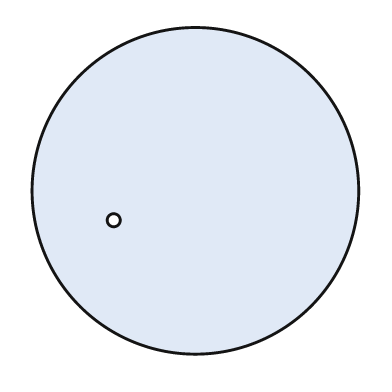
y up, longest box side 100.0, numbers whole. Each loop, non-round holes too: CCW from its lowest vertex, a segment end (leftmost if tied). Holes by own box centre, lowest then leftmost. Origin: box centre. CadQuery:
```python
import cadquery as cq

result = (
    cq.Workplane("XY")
    .moveTo(0.0, 0.0)
    .circle(50.0)
    .moveTo(-25.0, -9.0)
    .circle(2.0)
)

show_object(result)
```